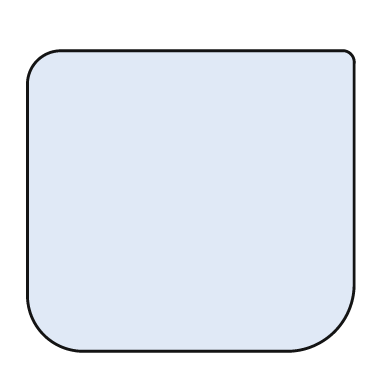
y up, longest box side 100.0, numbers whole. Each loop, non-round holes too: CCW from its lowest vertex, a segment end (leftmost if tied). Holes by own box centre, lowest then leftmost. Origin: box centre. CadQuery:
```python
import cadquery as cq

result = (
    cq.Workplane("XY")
    .moveTo(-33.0, -46.0)
    .lineTo(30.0, -46.0)
    .threePointArc((44.0, -40.0), (50.0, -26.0))
    .lineTo(50.0, 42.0)
    .threePointArc((49.0, 45.0), (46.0, 46.0))
    .lineTo(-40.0, 46.0)
    .threePointArc((-47.0, 43.0), (-50.0, 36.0))
    .lineTo(-50.0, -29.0)
    .threePointArc((-45.0, -41.0), (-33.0, -46.0))
    .close()
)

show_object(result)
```